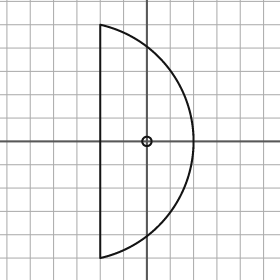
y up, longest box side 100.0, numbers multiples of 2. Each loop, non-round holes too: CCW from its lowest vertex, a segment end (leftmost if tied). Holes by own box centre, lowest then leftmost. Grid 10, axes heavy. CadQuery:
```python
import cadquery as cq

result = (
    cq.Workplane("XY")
    .moveTo(-20.0, -50.0)
    .threePointArc((20.0, 0.0), (-20.0, 50.0))
    .close()
    .moveTo(0.0, 0.0)
    .circle(2.0)
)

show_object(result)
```